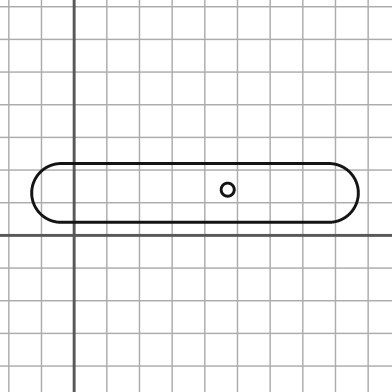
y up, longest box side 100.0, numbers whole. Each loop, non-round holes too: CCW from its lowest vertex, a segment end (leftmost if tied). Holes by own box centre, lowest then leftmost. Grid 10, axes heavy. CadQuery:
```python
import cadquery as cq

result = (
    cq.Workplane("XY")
    .moveTo(-4.0, 4.0)
    .lineTo(78.0, 4.0)
    .threePointArc((87.0, 13.0), (78.0, 22.0))
    .lineTo(-4.0, 22.0)
    .threePointArc((-13.0, 13.0), (-4.0, 4.0))
    .close()
    .moveTo(47.0, 14.0)
    .circle(2.0)
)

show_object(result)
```